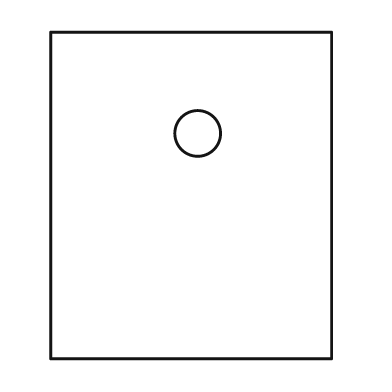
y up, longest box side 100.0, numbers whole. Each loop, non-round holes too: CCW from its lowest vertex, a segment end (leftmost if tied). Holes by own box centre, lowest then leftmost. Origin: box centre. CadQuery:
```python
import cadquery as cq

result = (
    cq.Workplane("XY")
    .moveTo(-43.0, -50.0)
    .lineTo(43.0, -50.0)
    .lineTo(43.0, 50.0)
    .lineTo(-43.0, 50.0)
    .close()
    .moveTo(2.0, 19.0)
    .circle(7.0)
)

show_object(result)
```